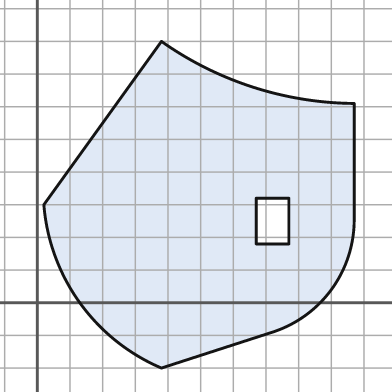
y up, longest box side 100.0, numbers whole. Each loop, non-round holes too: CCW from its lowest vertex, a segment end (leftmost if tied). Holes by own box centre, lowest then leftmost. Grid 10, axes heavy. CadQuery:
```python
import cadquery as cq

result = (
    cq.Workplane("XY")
    .moveTo(38.0, -20.0)
    .lineTo(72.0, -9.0)
    .threePointArc((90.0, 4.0), (97.0, 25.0))
    .lineTo(97.0, 61.0)
    .threePointArc((66.0, 66.0), (38.0, 80.0))
    .lineTo(2.0, 30.0)
    .threePointArc((13.0, 0.0), (38.0, -20.0))
    .close()
    .moveTo(67.0, 18.0)
    .lineTo(77.0, 18.0)
    .lineTo(77.0, 32.0)
    .lineTo(67.0, 32.0)
    .close()
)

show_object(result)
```